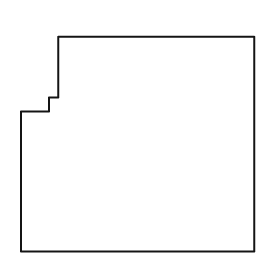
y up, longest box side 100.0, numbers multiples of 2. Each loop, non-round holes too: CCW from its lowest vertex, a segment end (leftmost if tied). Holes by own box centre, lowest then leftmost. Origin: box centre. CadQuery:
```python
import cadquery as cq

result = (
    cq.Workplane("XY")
    .moveTo(-50.0, -46.0)
    .lineTo(50.0, -46.0)
    .lineTo(50.0, 46.0)
    .lineTo(-34.0, 46.0)
    .lineTo(-34.0, 20.0)
    .lineTo(-38.0, 20.0)
    .lineTo(-38.0, 14.0)
    .lineTo(-50.0, 14.0)
    .close()
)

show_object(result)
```